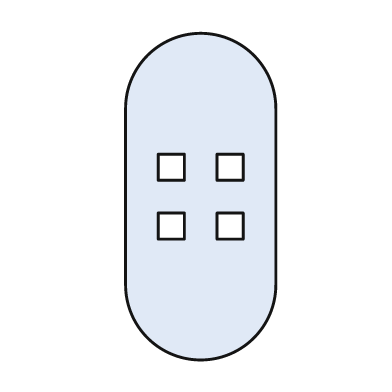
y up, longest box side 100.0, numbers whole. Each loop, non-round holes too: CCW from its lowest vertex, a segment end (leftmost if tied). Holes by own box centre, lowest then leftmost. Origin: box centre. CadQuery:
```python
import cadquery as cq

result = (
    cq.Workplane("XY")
    .moveTo(-23.0, -27.0)
    .threePointArc((0.0, -50.0), (23.0, -27.0))
    .lineTo(23.0, 27.0)
    .threePointArc((0.0, 50.0), (-23.0, 27.0))
    .close()
    .moveTo(-13.0, -13.0)
    .lineTo(-5.0, -13.0)
    .lineTo(-5.0, -5.0)
    .lineTo(-13.0, -5.0)
    .close()
    .moveTo(5.0, -13.0)
    .lineTo(13.0, -13.0)
    .lineTo(13.0, -5.0)
    .lineTo(5.0, -5.0)
    .close()
    .moveTo(-13.0, 5.0)
    .lineTo(-5.0, 5.0)
    .lineTo(-5.0, 13.0)
    .lineTo(-13.0, 13.0)
    .close()
    .moveTo(5.0, 5.0)
    .lineTo(13.0, 5.0)
    .lineTo(13.0, 13.0)
    .lineTo(5.0, 13.0)
    .close()
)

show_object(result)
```